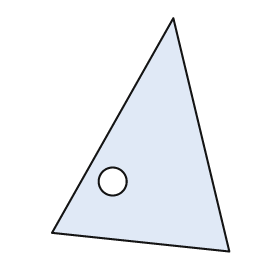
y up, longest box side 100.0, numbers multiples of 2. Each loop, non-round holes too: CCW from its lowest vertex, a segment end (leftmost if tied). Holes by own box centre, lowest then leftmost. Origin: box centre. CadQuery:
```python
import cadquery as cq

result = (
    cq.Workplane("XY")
    .moveTo(38.0, -50.0)
    .lineTo(14.0, 50.0)
    .lineTo(-38.0, -42.0)
    .close()
    .moveTo(-12.0, -20.0)
    .circle(6.0)
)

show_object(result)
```